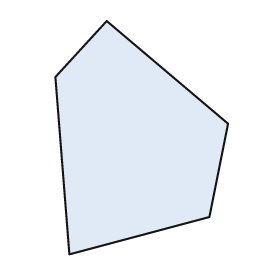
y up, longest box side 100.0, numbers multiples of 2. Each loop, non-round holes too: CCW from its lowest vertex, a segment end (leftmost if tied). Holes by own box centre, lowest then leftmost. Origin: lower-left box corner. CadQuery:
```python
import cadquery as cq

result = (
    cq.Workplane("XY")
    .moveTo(6.0, 0.0)
    .lineTo(66.0, 16.0)
    .lineTo(74.0, 56.0)
    .lineTo(22.0, 100.0)
    .lineTo(0.0, 76.0)
    .close()
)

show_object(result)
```